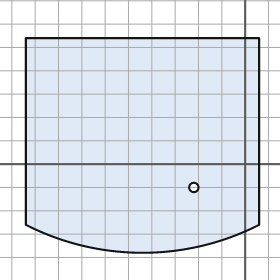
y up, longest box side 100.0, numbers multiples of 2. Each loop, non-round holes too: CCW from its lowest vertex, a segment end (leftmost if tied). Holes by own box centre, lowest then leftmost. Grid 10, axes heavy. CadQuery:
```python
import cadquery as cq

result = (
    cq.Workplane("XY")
    .moveTo(-94.0, -26.0)
    .threePointArc((-44.0, -38.0), (6.0, -26.0))
    .lineTo(6.0, 54.0)
    .lineTo(-94.0, 54.0)
    .close()
    .moveTo(-22.0, -10.0)
    .circle(2.0)
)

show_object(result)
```